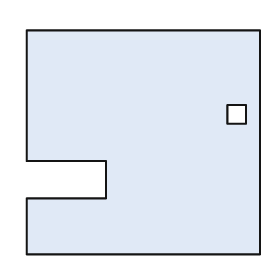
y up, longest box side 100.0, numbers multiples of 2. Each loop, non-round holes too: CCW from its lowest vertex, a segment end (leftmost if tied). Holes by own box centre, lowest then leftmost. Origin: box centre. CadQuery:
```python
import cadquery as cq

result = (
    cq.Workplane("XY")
    .moveTo(-50.0, -48.0)
    .lineTo(50.0, -48.0)
    .lineTo(50.0, 48.0)
    .lineTo(-50.0, 48.0)
    .lineTo(-50.0, -8.0)
    .lineTo(-16.0, -8.0)
    .lineTo(-16.0, -24.0)
    .lineTo(-50.0, -24.0)
    .close()
    .moveTo(36.0, 8.0)
    .lineTo(44.0, 8.0)
    .lineTo(44.0, 16.0)
    .lineTo(36.0, 16.0)
    .close()
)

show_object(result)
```